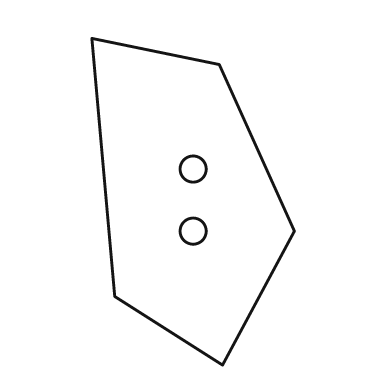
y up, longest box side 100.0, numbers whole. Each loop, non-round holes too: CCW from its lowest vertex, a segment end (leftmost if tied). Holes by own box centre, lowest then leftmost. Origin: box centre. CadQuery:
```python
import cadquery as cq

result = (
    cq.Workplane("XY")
    .moveTo(9.0, -50.0)
    .lineTo(31.0, -9.0)
    .lineTo(8.0, 42.0)
    .lineTo(-31.0, 50.0)
    .lineTo(-24.0, -29.0)
    .close()
    .moveTo(0.0, -9.0)
    .circle(4.0)
    .moveTo(0.0, 10.0)
    .circle(4.0)
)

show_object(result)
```